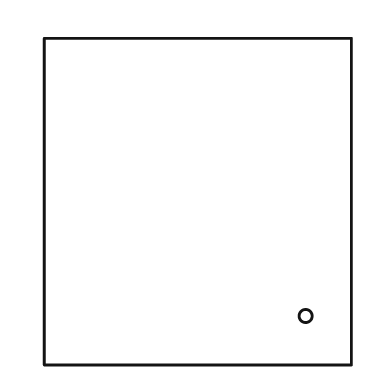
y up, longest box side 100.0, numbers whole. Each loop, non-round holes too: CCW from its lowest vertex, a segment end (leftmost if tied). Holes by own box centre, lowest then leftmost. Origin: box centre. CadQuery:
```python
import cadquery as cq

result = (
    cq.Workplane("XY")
    .moveTo(-47.0, -50.0)
    .lineTo(47.0, -50.0)
    .lineTo(47.0, 50.0)
    .lineTo(-47.0, 50.0)
    .close()
    .moveTo(33.0, -35.0)
    .circle(2.0)
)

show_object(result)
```